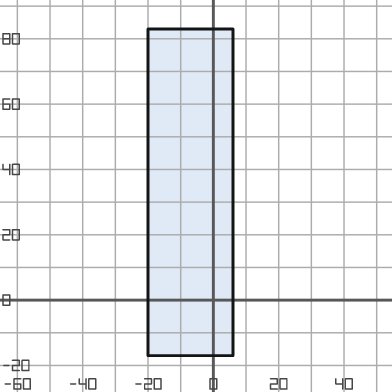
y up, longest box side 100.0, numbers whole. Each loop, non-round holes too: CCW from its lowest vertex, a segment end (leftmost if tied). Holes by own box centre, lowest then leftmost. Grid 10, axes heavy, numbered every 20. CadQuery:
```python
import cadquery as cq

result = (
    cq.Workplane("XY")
    .moveTo(-20.0, -17.0)
    .lineTo(6.0, -17.0)
    .lineTo(6.0, 83.0)
    .lineTo(-20.0, 83.0)
    .close()
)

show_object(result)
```